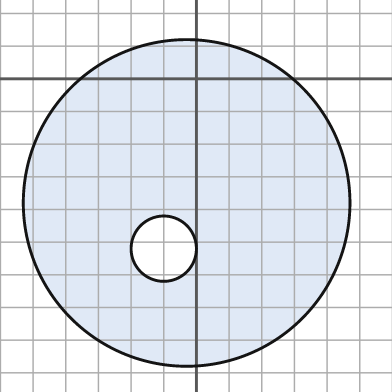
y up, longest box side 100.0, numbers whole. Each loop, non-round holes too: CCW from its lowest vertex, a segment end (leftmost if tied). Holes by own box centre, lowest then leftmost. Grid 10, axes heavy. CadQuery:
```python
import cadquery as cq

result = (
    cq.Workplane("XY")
    .moveTo(-3.0, -38.0)
    .circle(50.0)
    .moveTo(-10.0, -52.0)
    .circle(10.0)
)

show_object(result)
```